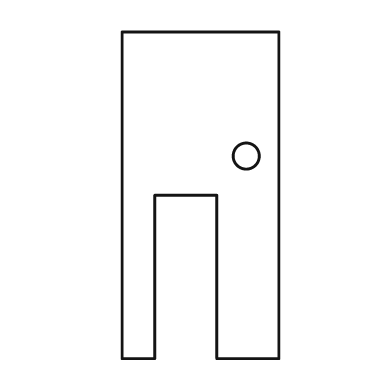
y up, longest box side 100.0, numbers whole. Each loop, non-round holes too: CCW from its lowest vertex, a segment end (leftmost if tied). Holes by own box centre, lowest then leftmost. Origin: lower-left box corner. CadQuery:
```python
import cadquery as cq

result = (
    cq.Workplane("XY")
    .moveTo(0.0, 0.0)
    .lineTo(10.0, 0.0)
    .lineTo(10.0, 50.0)
    .lineTo(29.0, 50.0)
    .lineTo(29.0, 0.0)
    .lineTo(48.0, 0.0)
    .lineTo(48.0, 100.0)
    .lineTo(0.0, 100.0)
    .close()
    .moveTo(38.0, 62.0)
    .circle(4.0)
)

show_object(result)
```